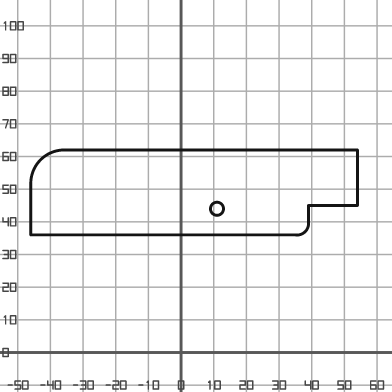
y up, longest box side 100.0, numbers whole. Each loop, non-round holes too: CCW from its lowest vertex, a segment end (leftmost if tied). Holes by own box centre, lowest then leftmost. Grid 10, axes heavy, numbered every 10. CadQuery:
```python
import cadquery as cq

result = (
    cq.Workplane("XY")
    .moveTo(-46.0, 36.0)
    .lineTo(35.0, 36.0)
    .threePointArc((38.0, 37.0), (39.0, 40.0))
    .lineTo(39.0, 45.0)
    .lineTo(54.0, 45.0)
    .lineTo(54.0, 62.0)
    .lineTo(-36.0, 62.0)
    .threePointArc((-43.0, 59.0), (-46.0, 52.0))
    .close()
    .moveTo(11.0, 44.0)
    .circle(2.0)
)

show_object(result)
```